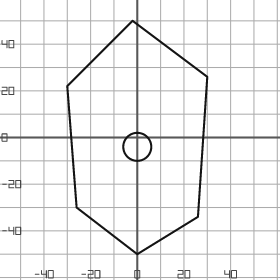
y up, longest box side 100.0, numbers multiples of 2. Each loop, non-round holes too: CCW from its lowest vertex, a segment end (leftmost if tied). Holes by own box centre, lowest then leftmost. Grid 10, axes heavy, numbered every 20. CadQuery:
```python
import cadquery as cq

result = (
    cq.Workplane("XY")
    .moveTo(0.0, -50.0)
    .lineTo(26.0, -34.0)
    .lineTo(30.0, 26.0)
    .lineTo(-2.0, 50.0)
    .lineTo(-30.0, 22.0)
    .lineTo(-26.0, -30.0)
    .close()
    .moveTo(0.0, -4.0)
    .circle(6.0)
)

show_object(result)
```